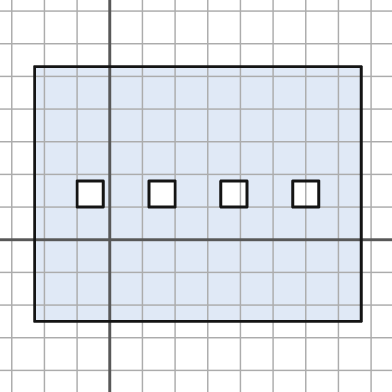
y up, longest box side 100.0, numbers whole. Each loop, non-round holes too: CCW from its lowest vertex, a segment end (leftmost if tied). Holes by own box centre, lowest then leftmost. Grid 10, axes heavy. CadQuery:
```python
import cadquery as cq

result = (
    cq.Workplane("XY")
    .moveTo(-23.0, -25.0)
    .lineTo(77.0, -25.0)
    .lineTo(77.0, 53.0)
    .lineTo(-23.0, 53.0)
    .close()
    .moveTo(-10.0, 10.0)
    .lineTo(-2.0, 10.0)
    .lineTo(-2.0, 18.0)
    .lineTo(-10.0, 18.0)
    .close()
    .moveTo(12.0, 10.0)
    .lineTo(20.0, 10.0)
    .lineTo(20.0, 18.0)
    .lineTo(12.0, 18.0)
    .close()
    .moveTo(34.0, 10.0)
    .lineTo(42.0, 10.0)
    .lineTo(42.0, 18.0)
    .lineTo(34.0, 18.0)
    .close()
    .moveTo(56.0, 10.0)
    .lineTo(64.0, 10.0)
    .lineTo(64.0, 18.0)
    .lineTo(56.0, 18.0)
    .close()
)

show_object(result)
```